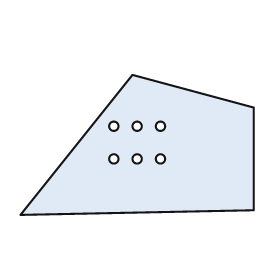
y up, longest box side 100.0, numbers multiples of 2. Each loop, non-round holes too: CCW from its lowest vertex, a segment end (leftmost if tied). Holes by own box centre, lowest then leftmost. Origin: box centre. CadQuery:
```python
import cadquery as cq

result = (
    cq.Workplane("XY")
    .moveTo(-50.0, -30.0)
    .lineTo(50.0, -28.0)
    .lineTo(50.0, 16.0)
    .lineTo(-2.0, 30.0)
    .close()
    .moveTo(-10.0, -6.0)
    .circle(2.0)
    .moveTo(0.0, -6.0)
    .circle(2.0)
    .moveTo(10.0, -6.0)
    .circle(2.0)
    .moveTo(-10.0, 8.0)
    .circle(2.0)
    .moveTo(0.0, 8.0)
    .circle(2.0)
    .moveTo(10.0, 8.0)
    .circle(2.0)
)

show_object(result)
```